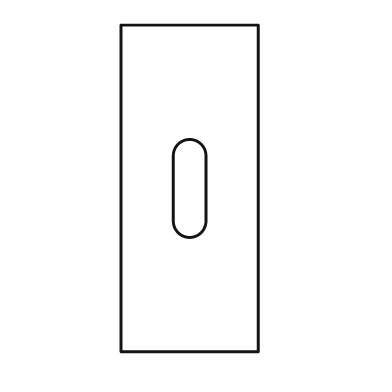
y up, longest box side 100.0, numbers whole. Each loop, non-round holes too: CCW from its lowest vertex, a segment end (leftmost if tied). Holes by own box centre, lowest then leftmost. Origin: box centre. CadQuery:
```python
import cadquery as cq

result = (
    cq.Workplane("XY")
    .moveTo(-21.0, -50.0)
    .lineTo(21.0, -50.0)
    .lineTo(21.0, 50.0)
    .lineTo(-21.0, 50.0)
    .close()
    .moveTo(-5.0, -10.0)
    .threePointArc((0.0, -15.0), (5.0, -10.0))
    .lineTo(5.0, 10.0)
    .threePointArc((0.0, 15.0), (-5.0, 10.0))
    .close()
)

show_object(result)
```